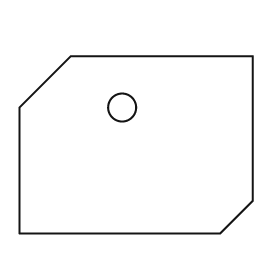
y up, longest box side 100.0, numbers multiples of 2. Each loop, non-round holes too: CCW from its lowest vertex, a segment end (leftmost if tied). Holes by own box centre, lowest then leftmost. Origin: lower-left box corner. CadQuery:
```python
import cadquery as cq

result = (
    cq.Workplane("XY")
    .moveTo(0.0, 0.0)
    .lineTo(86.0, 0.0)
    .lineTo(100.0, 14.0)
    .lineTo(100.0, 76.0)
    .lineTo(22.0, 76.0)
    .lineTo(0.0, 54.0)
    .close()
    .moveTo(44.0, 54.0)
    .circle(6.0)
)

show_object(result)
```